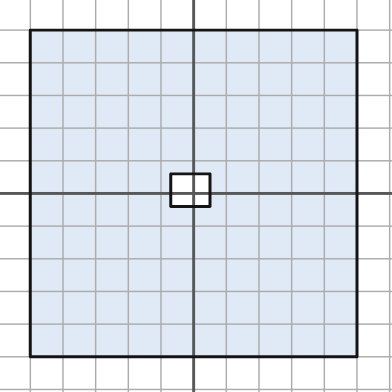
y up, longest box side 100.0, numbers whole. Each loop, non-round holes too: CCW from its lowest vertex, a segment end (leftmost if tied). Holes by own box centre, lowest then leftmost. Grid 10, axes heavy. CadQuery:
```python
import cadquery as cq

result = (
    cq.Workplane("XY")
    .moveTo(-50.0, -50.0)
    .lineTo(50.0, -50.0)
    .lineTo(50.0, 50.0)
    .lineTo(-50.0, 50.0)
    .close()
    .moveTo(-7.0, -4.0)
    .lineTo(5.0, -4.0)
    .lineTo(5.0, 6.0)
    .lineTo(-7.0, 6.0)
    .close()
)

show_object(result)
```